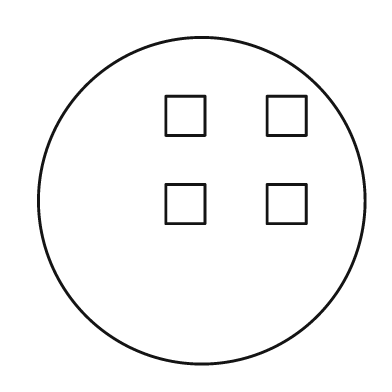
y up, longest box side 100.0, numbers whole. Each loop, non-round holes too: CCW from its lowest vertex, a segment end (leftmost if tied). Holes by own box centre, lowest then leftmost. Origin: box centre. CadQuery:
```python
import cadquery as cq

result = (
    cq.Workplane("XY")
    .moveTo(0.0, 0.0)
    .circle(50.0)
    .moveTo(-11.0, -7.0)
    .lineTo(1.0, -7.0)
    .lineTo(1.0, 5.0)
    .lineTo(-11.0, 5.0)
    .close()
    .moveTo(20.0, -7.0)
    .lineTo(32.0, -7.0)
    .lineTo(32.0, 5.0)
    .lineTo(20.0, 5.0)
    .close()
    .moveTo(-11.0, 20.0)
    .lineTo(1.0, 20.0)
    .lineTo(1.0, 32.0)
    .lineTo(-11.0, 32.0)
    .close()
    .moveTo(20.0, 20.0)
    .lineTo(32.0, 20.0)
    .lineTo(32.0, 32.0)
    .lineTo(20.0, 32.0)
    .close()
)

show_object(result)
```